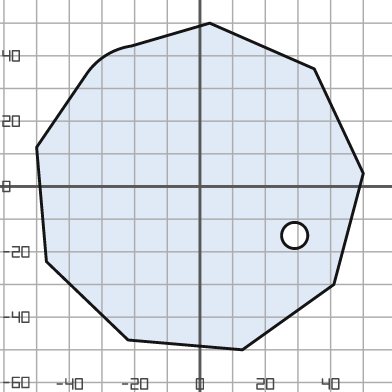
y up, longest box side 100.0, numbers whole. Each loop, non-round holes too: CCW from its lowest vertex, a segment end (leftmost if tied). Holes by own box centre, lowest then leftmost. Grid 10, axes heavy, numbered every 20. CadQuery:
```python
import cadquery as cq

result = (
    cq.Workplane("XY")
    .moveTo(13.0, -50.0)
    .lineTo(41.0, -30.0)
    .lineTo(50.0, 4.0)
    .lineTo(35.0, 36.0)
    .lineTo(3.0, 50.0)
    .lineTo(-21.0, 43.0)
    .threePointArc((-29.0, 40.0), (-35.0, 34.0))
    .lineTo(-50.0, 12.0)
    .lineTo(-47.0, -23.0)
    .lineTo(-22.0, -47.0)
    .close()
    .moveTo(29.0, -15.0)
    .circle(4.0)
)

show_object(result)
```